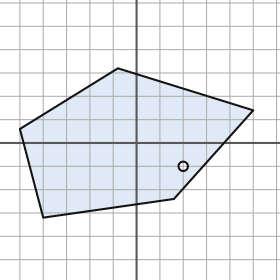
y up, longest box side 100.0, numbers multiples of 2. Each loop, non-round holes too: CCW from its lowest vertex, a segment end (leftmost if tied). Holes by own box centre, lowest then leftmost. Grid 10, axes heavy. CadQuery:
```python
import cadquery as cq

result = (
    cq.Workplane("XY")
    .moveTo(-40.0, -32.0)
    .lineTo(16.0, -24.0)
    .lineTo(50.0, 14.0)
    .lineTo(-8.0, 32.0)
    .lineTo(-50.0, 6.0)
    .close()
    .moveTo(20.0, -10.0)
    .circle(2.0)
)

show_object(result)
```